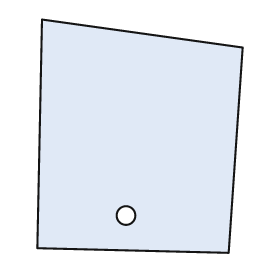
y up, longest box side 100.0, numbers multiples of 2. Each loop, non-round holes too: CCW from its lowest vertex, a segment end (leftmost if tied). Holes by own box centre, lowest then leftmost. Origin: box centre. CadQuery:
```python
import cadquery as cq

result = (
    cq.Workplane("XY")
    .moveTo(38.0, -50.0)
    .lineTo(44.0, 38.0)
    .lineTo(-42.0, 50.0)
    .lineTo(-44.0, -48.0)
    .close()
    .moveTo(-6.0, -34.0)
    .circle(4.0)
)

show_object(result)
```